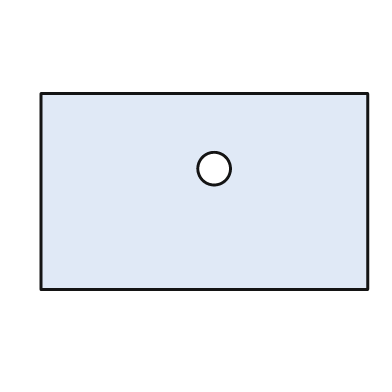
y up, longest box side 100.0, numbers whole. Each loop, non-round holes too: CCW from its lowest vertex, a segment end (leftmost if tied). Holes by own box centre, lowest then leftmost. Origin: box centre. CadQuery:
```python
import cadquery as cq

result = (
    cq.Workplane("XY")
    .moveTo(-50.0, -30.0)
    .lineTo(50.0, -30.0)
    .lineTo(50.0, 30.0)
    .lineTo(-50.0, 30.0)
    .close()
    .moveTo(3.0, 7.0)
    .circle(5.0)
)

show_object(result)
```